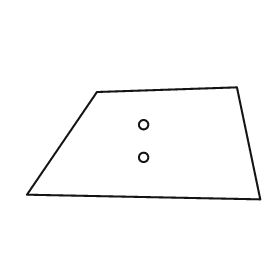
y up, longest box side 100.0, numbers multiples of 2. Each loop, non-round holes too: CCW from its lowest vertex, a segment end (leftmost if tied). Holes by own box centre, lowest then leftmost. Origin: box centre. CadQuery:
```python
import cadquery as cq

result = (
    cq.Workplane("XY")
    .moveTo(50.0, -24.0)
    .lineTo(40.0, 24.0)
    .lineTo(-20.0, 22.0)
    .lineTo(-50.0, -22.0)
    .close()
    .moveTo(0.0, -6.0)
    .circle(2.0)
    .moveTo(0.0, 8.0)
    .circle(2.0)
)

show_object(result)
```